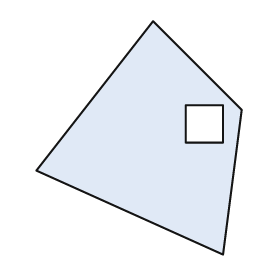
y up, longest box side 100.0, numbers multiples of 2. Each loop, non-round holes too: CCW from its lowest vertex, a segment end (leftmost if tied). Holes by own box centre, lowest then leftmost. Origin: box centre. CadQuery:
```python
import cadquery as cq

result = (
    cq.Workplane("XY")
    .moveTo(36.0, -50.0)
    .lineTo(44.0, 12.0)
    .lineTo(6.0, 50.0)
    .lineTo(-44.0, -14.0)
    .close()
    .moveTo(20.0, -2.0)
    .lineTo(36.0, -2.0)
    .lineTo(36.0, 14.0)
    .lineTo(20.0, 14.0)
    .close()
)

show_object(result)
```